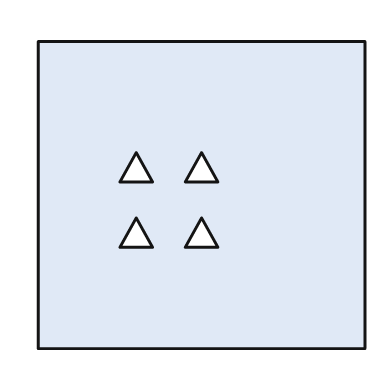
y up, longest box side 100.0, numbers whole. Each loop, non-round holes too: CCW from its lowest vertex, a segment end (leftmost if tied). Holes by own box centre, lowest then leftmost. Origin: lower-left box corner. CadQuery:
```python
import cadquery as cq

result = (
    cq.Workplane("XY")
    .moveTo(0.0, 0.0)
    .lineTo(100.0, 0.0)
    .lineTo(100.0, 94.0)
    .lineTo(0.0, 94.0)
    .close()
    .moveTo(25.0, 31.0)
    .lineTo(35.0, 31.0)
    .lineTo(30.0, 40.0)
    .close()
    .moveTo(45.0, 31.0)
    .lineTo(55.0, 31.0)
    .lineTo(50.0, 40.0)
    .close()
    .moveTo(25.0, 51.0)
    .lineTo(35.0, 51.0)
    .lineTo(30.0, 60.0)
    .close()
    .moveTo(45.0, 51.0)
    .lineTo(55.0, 51.0)
    .lineTo(50.0, 60.0)
    .close()
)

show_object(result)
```